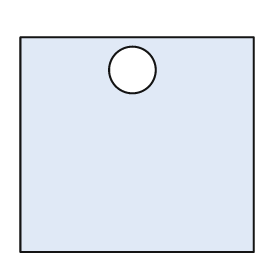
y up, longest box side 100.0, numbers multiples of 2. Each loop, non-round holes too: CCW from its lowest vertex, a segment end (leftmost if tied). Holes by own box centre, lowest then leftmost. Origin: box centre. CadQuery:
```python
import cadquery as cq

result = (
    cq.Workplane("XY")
    .moveTo(-50.0, -46.0)
    .lineTo(50.0, -46.0)
    .lineTo(50.0, 46.0)
    .lineTo(-50.0, 46.0)
    .close()
    .moveTo(-2.0, 32.0)
    .circle(10.0)
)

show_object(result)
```